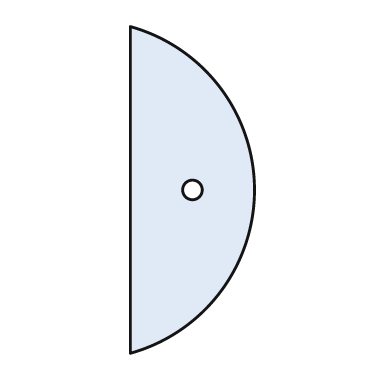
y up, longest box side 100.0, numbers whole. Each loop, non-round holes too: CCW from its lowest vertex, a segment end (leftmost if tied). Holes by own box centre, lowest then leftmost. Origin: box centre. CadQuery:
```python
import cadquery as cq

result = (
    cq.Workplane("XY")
    .moveTo(-19.0, -50.0)
    .threePointArc((19.0, 0.0), (-19.0, 50.0))
    .close()
    .moveTo(0.0, 0.0)
    .circle(3.0)
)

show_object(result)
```